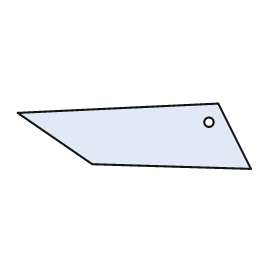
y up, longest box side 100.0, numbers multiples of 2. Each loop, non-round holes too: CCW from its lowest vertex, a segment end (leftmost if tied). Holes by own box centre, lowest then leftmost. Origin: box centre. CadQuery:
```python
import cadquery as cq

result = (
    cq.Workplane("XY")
    .moveTo(50.0, -14.0)
    .lineTo(36.0, 14.0)
    .lineTo(-50.0, 10.0)
    .lineTo(-18.0, -12.0)
    .close()
    .moveTo(32.0, 6.0)
    .circle(2.0)
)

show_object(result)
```